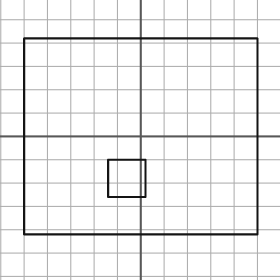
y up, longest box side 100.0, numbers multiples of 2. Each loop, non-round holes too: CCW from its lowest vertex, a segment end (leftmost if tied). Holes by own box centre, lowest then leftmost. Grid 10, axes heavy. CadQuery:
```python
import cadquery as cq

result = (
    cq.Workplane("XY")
    .moveTo(-50.0, -42.0)
    .lineTo(50.0, -42.0)
    .lineTo(50.0, 42.0)
    .lineTo(-50.0, 42.0)
    .close()
    .moveTo(-14.0, -26.0)
    .lineTo(2.0, -26.0)
    .lineTo(2.0, -10.0)
    .lineTo(-14.0, -10.0)
    .close()
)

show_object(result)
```